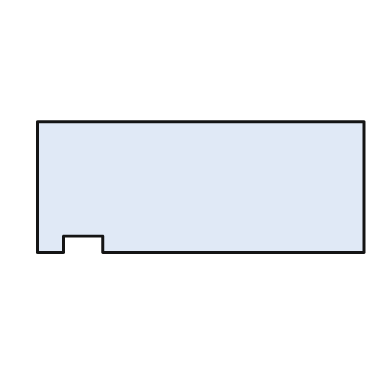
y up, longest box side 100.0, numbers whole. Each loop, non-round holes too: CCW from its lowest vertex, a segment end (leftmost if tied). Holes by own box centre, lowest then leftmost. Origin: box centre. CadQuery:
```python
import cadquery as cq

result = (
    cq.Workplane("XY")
    .moveTo(-50.0, -20.0)
    .lineTo(-42.0, -20.0)
    .lineTo(-42.0, -15.0)
    .lineTo(-30.0, -15.0)
    .lineTo(-30.0, -20.0)
    .lineTo(50.0, -20.0)
    .lineTo(50.0, 20.0)
    .lineTo(-50.0, 20.0)
    .close()
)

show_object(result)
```